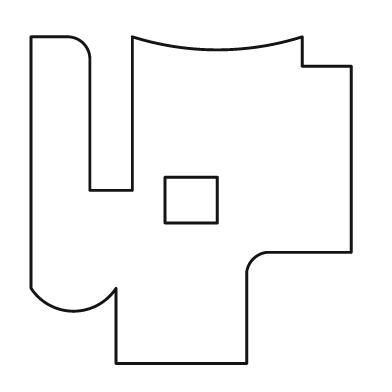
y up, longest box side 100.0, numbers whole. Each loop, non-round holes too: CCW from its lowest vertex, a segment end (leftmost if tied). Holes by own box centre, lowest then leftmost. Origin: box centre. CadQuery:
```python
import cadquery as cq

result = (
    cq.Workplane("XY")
    .moveTo(-23.0, -50.0)
    .lineTo(17.0, -50.0)
    .lineTo(17.0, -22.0)
    .threePointArc((19.0, -18.0), (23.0, -16.0))
    .lineTo(49.0, -16.0)
    .lineTo(49.0, 41.0)
    .lineTo(34.0, 41.0)
    .lineTo(34.0, 50.0)
    .threePointArc((8.0, 46.0), (-18.0, 50.0))
    .lineTo(-18.0, 3.0)
    .lineTo(-31.0, 3.0)
    .lineTo(-31.0, 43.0)
    .threePointArc((-33.0, 48.0), (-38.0, 50.0))
    .lineTo(-49.0, 50.0)
    .lineTo(-49.0, -27.0)
    .threePointArc((-36.0, -34.0), (-23.0, -27.0))
    .close()
    .moveTo(-8.0, -7.0)
    .lineTo(8.0, -7.0)
    .lineTo(8.0, 7.0)
    .lineTo(-8.0, 7.0)
    .close()
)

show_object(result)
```